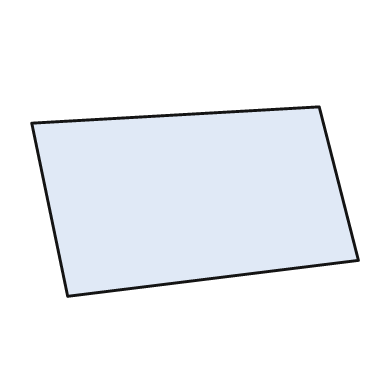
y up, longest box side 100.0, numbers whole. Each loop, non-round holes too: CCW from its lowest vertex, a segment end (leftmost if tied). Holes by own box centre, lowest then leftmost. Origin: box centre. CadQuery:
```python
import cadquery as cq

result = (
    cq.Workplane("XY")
    .moveTo(-39.0, -29.0)
    .lineTo(50.0, -18.0)
    .lineTo(38.0, 29.0)
    .lineTo(-50.0, 24.0)
    .close()
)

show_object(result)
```